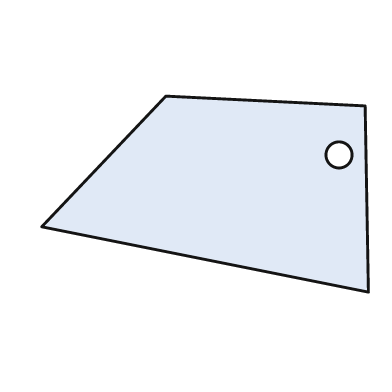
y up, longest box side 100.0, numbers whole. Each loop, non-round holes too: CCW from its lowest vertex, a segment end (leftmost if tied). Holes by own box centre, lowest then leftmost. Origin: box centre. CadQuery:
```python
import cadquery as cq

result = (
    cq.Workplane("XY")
    .moveTo(50.0, -30.0)
    .lineTo(49.0, 27.0)
    .lineTo(-12.0, 30.0)
    .lineTo(-50.0, -10.0)
    .close()
    .moveTo(41.0, 12.0)
    .circle(4.0)
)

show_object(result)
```